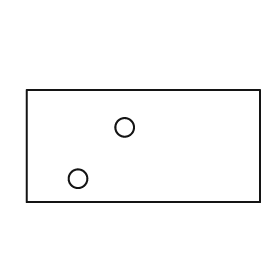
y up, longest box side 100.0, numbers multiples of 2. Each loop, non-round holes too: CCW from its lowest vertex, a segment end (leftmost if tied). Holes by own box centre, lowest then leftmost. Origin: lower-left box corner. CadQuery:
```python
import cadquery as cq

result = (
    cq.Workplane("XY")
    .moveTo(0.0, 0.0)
    .lineTo(100.0, 0.0)
    .lineTo(100.0, 48.0)
    .lineTo(0.0, 48.0)
    .close()
    .moveTo(22.0, 10.0)
    .circle(4.0)
    .moveTo(42.0, 32.0)
    .circle(4.0)
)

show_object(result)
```